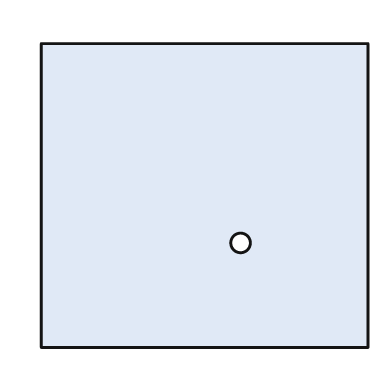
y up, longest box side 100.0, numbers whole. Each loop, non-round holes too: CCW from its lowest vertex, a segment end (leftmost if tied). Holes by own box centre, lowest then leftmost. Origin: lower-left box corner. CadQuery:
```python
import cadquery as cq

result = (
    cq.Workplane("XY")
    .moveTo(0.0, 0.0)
    .lineTo(100.0, 0.0)
    .lineTo(100.0, 93.0)
    .lineTo(0.0, 93.0)
    .close()
    .moveTo(61.0, 32.0)
    .circle(3.0)
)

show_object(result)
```